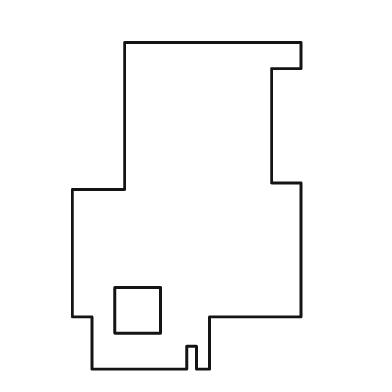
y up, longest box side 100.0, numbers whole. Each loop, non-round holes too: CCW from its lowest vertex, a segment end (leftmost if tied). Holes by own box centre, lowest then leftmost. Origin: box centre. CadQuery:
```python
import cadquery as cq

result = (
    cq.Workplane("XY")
    .moveTo(-29.0, -50.0)
    .lineTo(0.0, -50.0)
    .lineTo(0.0, -43.0)
    .lineTo(3.0, -43.0)
    .lineTo(3.0, -50.0)
    .lineTo(7.0, -50.0)
    .lineTo(7.0, -34.0)
    .lineTo(35.0, -34.0)
    .lineTo(35.0, 7.0)
    .lineTo(26.0, 7.0)
    .lineTo(26.0, 42.0)
    .lineTo(35.0, 42.0)
    .lineTo(35.0, 50.0)
    .lineTo(-19.0, 50.0)
    .lineTo(-19.0, 5.0)
    .lineTo(-35.0, 5.0)
    .lineTo(-35.0, -34.0)
    .lineTo(-29.0, -34.0)
    .close()
    .moveTo(-22.0, -39.0)
    .lineTo(-8.0, -39.0)
    .lineTo(-8.0, -25.0)
    .lineTo(-22.0, -25.0)
    .close()
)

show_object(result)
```